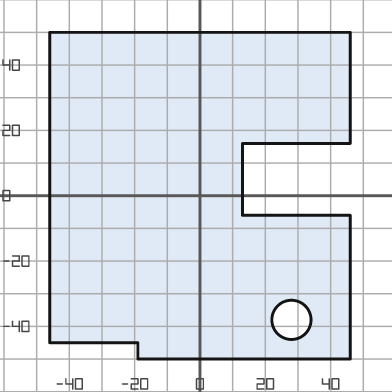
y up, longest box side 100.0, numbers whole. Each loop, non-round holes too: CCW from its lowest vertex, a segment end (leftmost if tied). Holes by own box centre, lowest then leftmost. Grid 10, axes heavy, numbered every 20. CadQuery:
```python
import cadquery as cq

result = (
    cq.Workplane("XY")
    .moveTo(-19.0, -50.0)
    .lineTo(46.0, -50.0)
    .lineTo(46.0, -6.0)
    .lineTo(13.0, -6.0)
    .lineTo(13.0, 16.0)
    .lineTo(46.0, 16.0)
    .lineTo(46.0, 50.0)
    .lineTo(-46.0, 50.0)
    .lineTo(-46.0, -45.0)
    .lineTo(-19.0, -45.0)
    .close()
    .moveTo(28.0, -38.0)
    .circle(6.0)
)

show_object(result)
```